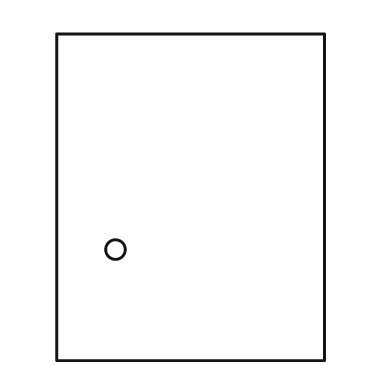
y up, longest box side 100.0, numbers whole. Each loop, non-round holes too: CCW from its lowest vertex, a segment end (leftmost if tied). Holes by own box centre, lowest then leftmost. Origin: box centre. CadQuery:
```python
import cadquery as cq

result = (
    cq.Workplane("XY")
    .moveTo(-41.0, -50.0)
    .lineTo(41.0, -50.0)
    .lineTo(41.0, 50.0)
    .lineTo(-41.0, 50.0)
    .close()
    .moveTo(-23.0, -16.0)
    .circle(3.0)
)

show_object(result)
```